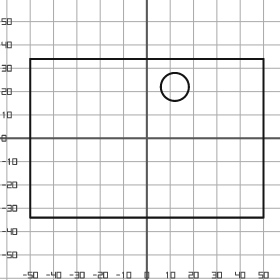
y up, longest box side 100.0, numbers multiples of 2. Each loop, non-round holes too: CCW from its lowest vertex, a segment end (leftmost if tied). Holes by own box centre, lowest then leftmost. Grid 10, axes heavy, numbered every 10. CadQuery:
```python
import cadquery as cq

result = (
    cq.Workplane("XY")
    .moveTo(-50.0, -34.0)
    .lineTo(50.0, -34.0)
    .lineTo(50.0, 34.0)
    .lineTo(-50.0, 34.0)
    .close()
    .moveTo(12.0, 22.0)
    .circle(6.0)
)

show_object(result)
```